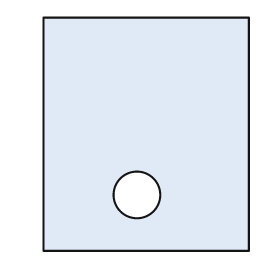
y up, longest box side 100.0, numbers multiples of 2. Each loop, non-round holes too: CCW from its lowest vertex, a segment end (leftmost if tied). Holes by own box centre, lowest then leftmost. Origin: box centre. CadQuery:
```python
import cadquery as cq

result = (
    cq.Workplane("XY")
    .moveTo(-44.0, -50.0)
    .lineTo(44.0, -50.0)
    .lineTo(44.0, 50.0)
    .lineTo(-44.0, 50.0)
    .close()
    .moveTo(-4.0, -26.0)
    .circle(10.0)
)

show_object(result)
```